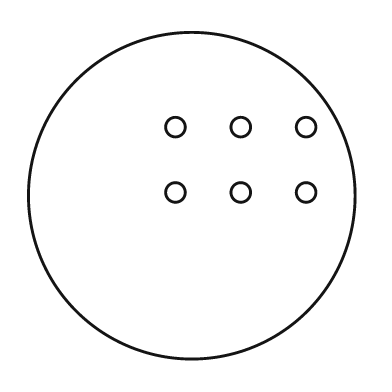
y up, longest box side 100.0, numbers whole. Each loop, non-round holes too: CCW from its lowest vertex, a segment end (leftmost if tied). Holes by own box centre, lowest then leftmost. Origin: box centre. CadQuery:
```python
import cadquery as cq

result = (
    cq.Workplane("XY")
    .moveTo(0.0, 0.0)
    .circle(50.0)
    .moveTo(-5.0, 1.0)
    .circle(3.0)
    .moveTo(15.0, 1.0)
    .circle(3.0)
    .moveTo(35.0, 1.0)
    .circle(3.0)
    .moveTo(-5.0, 21.0)
    .circle(3.0)
    .moveTo(15.0, 21.0)
    .circle(3.0)
    .moveTo(35.0, 21.0)
    .circle(3.0)
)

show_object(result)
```